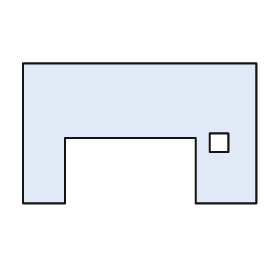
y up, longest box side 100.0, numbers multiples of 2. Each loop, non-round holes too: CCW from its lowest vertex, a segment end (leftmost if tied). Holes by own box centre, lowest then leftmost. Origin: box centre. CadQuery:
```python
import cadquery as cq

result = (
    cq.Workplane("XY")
    .moveTo(-50.0, -30.0)
    .lineTo(-32.0, -30.0)
    .lineTo(-32.0, -2.0)
    .lineTo(24.0, -2.0)
    .lineTo(24.0, -30.0)
    .lineTo(50.0, -30.0)
    .lineTo(50.0, 30.0)
    .lineTo(-50.0, 30.0)
    .close()
    .moveTo(30.0, -8.0)
    .lineTo(38.0, -8.0)
    .lineTo(38.0, 0.0)
    .lineTo(30.0, 0.0)
    .close()
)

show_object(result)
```